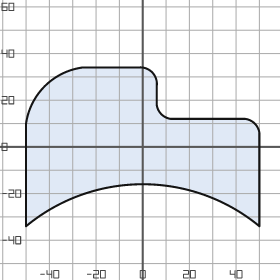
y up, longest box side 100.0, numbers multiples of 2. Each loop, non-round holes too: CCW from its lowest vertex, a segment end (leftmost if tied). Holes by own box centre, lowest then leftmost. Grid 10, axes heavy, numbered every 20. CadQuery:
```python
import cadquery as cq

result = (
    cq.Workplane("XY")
    .moveTo(-50.0, -34.0)
    .threePointArc((0.0, -16.0), (50.0, -34.0))
    .lineTo(50.0, 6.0)
    .threePointArc((48.0, 10.0), (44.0, 12.0))
    .lineTo(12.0, 12.0)
    .threePointArc((8.0, 14.0), (6.0, 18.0))
    .lineTo(6.0, 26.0)
    .threePointArc((4.0, 32.0), (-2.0, 34.0))
    .lineTo(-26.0, 34.0)
    .threePointArc((-42.0, 26.0), (-50.0, 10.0))
    .close()
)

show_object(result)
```